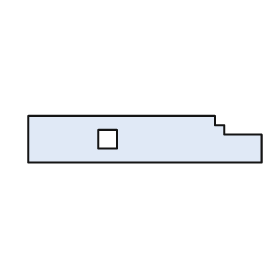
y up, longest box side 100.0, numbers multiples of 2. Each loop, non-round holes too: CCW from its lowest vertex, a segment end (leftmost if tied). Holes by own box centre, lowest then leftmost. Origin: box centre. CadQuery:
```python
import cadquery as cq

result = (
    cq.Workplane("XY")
    .moveTo(-50.0, -10.0)
    .lineTo(50.0, -10.0)
    .lineTo(50.0, 2.0)
    .lineTo(34.0, 2.0)
    .lineTo(34.0, 6.0)
    .lineTo(30.0, 6.0)
    .lineTo(30.0, 10.0)
    .lineTo(-50.0, 10.0)
    .close()
    .moveTo(-20.0, -4.0)
    .lineTo(-12.0, -4.0)
    .lineTo(-12.0, 4.0)
    .lineTo(-20.0, 4.0)
    .close()
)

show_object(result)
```